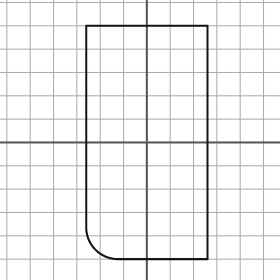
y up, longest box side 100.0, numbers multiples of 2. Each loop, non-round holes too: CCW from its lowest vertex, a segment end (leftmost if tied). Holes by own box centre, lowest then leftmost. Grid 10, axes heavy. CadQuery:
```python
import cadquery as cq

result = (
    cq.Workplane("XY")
    .moveTo(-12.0, -50.0)
    .lineTo(26.0, -50.0)
    .lineTo(26.0, 50.0)
    .lineTo(-26.0, 50.0)
    .lineTo(-26.0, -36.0)
    .threePointArc((-22.0, -46.0), (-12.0, -50.0))
    .close()
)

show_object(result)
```